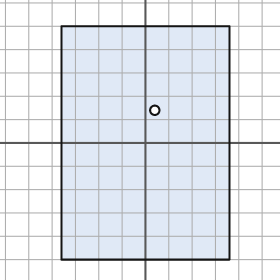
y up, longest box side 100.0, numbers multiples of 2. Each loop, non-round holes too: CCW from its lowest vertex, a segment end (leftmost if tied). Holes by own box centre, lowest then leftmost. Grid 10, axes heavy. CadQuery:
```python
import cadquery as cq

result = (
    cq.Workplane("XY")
    .moveTo(-36.0, -50.0)
    .lineTo(36.0, -50.0)
    .lineTo(36.0, 50.0)
    .lineTo(-36.0, 50.0)
    .close()
    .moveTo(4.0, 14.0)
    .circle(2.0)
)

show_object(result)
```